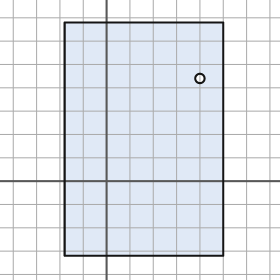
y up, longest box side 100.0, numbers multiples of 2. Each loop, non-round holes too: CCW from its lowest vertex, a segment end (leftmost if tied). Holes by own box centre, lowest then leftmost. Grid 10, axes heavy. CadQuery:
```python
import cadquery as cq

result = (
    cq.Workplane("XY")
    .moveTo(-18.0, -32.0)
    .lineTo(50.0, -32.0)
    .lineTo(50.0, 68.0)
    .lineTo(-18.0, 68.0)
    .close()
    .moveTo(40.0, 44.0)
    .circle(2.0)
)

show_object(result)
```